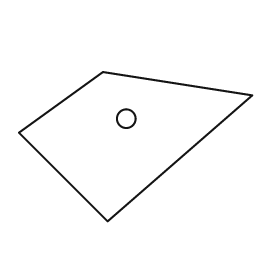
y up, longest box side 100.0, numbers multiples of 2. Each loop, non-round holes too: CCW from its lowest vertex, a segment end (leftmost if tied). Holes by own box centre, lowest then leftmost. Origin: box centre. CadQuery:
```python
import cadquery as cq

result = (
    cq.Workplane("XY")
    .moveTo(-12.0, -32.0)
    .lineTo(50.0, 22.0)
    .lineTo(-14.0, 32.0)
    .lineTo(-50.0, 6.0)
    .close()
    .moveTo(-4.0, 12.0)
    .circle(4.0)
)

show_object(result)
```